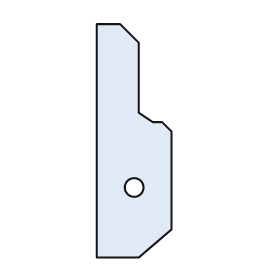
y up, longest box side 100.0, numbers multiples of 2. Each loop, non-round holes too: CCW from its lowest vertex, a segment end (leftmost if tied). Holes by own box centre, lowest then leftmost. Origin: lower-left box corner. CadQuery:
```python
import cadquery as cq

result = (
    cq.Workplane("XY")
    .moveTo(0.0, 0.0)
    .lineTo(18.0, 0.0)
    .lineTo(32.0, 12.0)
    .lineTo(32.0, 54.0)
    .lineTo(28.0, 58.0)
    .lineTo(24.0, 58.0)
    .lineTo(18.0, 62.0)
    .lineTo(18.0, 92.0)
    .lineTo(10.0, 100.0)
    .lineTo(0.0, 100.0)
    .close()
    .moveTo(16.0, 30.0)
    .circle(4.0)
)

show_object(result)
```